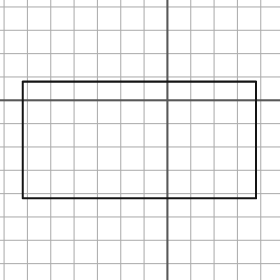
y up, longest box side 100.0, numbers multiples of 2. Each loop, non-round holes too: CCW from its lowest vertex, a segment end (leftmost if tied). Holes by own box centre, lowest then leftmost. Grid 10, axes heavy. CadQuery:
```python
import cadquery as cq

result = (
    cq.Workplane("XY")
    .moveTo(-62.0, -42.0)
    .lineTo(38.0, -42.0)
    .lineTo(38.0, 8.0)
    .lineTo(-62.0, 8.0)
    .close()
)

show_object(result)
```